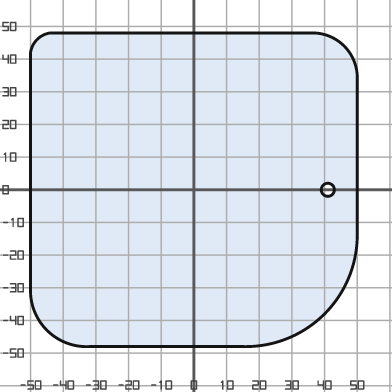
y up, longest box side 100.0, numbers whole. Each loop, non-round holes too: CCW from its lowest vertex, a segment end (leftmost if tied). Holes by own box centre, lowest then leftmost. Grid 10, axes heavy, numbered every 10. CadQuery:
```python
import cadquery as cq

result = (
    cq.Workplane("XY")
    .moveTo(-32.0, -48.0)
    .lineTo(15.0, -48.0)
    .threePointArc((40.0, -38.0), (50.0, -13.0))
    .lineTo(50.0, 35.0)
    .threePointArc((46.0, 44.0), (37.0, 48.0))
    .lineTo(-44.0, 48.0)
    .threePointArc((-48.0, 46.0), (-50.0, 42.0))
    .lineTo(-50.0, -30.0)
    .threePointArc((-45.0, -43.0), (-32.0, -48.0))
    .close()
    .moveTo(41.0, 0.0)
    .circle(2.0)
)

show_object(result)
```